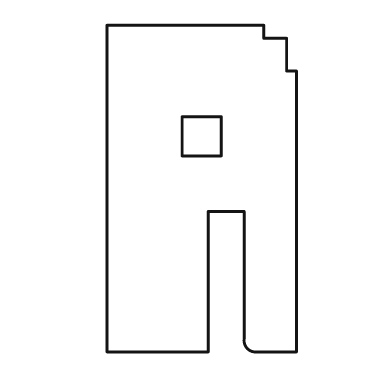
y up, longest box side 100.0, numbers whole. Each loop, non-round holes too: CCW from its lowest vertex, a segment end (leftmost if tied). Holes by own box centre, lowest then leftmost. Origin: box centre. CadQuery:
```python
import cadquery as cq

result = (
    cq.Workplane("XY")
    .moveTo(-29.0, -50.0)
    .lineTo(2.0, -50.0)
    .lineTo(2.0, -7.0)
    .lineTo(13.0, -7.0)
    .lineTo(13.0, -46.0)
    .threePointArc((14.0, -49.0), (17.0, -50.0))
    .lineTo(29.0, -50.0)
    .lineTo(29.0, 36.0)
    .lineTo(26.0, 36.0)
    .lineTo(26.0, 46.0)
    .lineTo(19.0, 46.0)
    .lineTo(19.0, 50.0)
    .lineTo(-29.0, 50.0)
    .close()
    .moveTo(-6.0, 10.0)
    .lineTo(6.0, 10.0)
    .lineTo(6.0, 22.0)
    .lineTo(-6.0, 22.0)
    .close()
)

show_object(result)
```